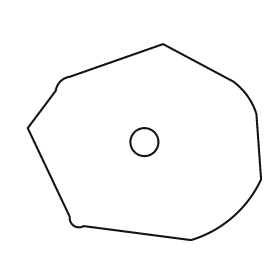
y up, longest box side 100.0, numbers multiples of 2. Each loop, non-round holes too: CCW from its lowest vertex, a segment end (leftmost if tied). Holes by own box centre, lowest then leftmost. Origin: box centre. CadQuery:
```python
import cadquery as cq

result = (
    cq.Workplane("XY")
    .moveTo(20.0, -42.0)
    .threePointArc((38.0, -32.0), (50.0, -16.0))
    .lineTo(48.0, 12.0)
    .threePointArc((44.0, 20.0), (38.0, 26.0))
    .lineTo(8.0, 42.0)
    .lineTo(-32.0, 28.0)
    .threePointArc((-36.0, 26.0), (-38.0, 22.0))
    .lineTo(-50.0, 6.0)
    .lineTo(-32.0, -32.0)
    .threePointArc((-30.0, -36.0), (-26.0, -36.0))
    .close()
    .moveTo(0.0, 0.0)
    .circle(6.0)
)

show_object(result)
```